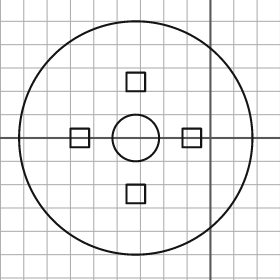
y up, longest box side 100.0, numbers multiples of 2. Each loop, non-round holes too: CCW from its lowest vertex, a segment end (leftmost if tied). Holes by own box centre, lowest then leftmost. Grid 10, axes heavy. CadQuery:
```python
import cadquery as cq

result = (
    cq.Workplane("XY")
    .moveTo(-32.0, 0.0)
    .circle(50.0)
    .moveTo(-36.0, -28.0)
    .lineTo(-28.0, -28.0)
    .lineTo(-28.0, -20.0)
    .lineTo(-36.0, -20.0)
    .close()
    .moveTo(-60.0, -4.0)
    .lineTo(-52.0, -4.0)
    .lineTo(-52.0, 4.0)
    .lineTo(-60.0, 4.0)
    .close()
    .moveTo(-32.0, 0.0)
    .circle(10.0)
    .moveTo(-12.0, -4.0)
    .lineTo(-4.0, -4.0)
    .lineTo(-4.0, 4.0)
    .lineTo(-12.0, 4.0)
    .close()
    .moveTo(-36.0, 20.0)
    .lineTo(-28.0, 20.0)
    .lineTo(-28.0, 28.0)
    .lineTo(-36.0, 28.0)
    .close()
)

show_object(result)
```